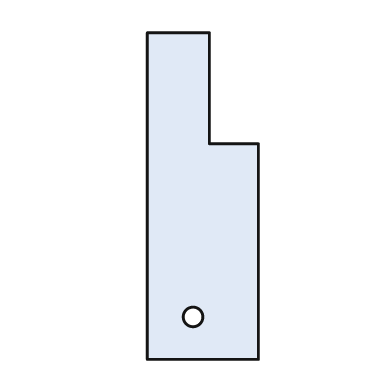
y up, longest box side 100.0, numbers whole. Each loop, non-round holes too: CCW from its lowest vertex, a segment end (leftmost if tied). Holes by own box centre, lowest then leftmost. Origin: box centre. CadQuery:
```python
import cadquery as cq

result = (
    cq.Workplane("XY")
    .moveTo(-17.0, -50.0)
    .lineTo(17.0, -50.0)
    .lineTo(17.0, 16.0)
    .lineTo(2.0, 16.0)
    .lineTo(2.0, 50.0)
    .lineTo(-17.0, 50.0)
    .close()
    .moveTo(-3.0, -37.0)
    .circle(3.0)
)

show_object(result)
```